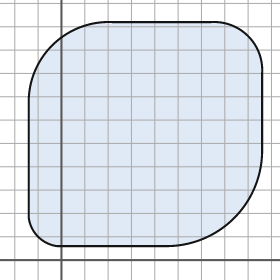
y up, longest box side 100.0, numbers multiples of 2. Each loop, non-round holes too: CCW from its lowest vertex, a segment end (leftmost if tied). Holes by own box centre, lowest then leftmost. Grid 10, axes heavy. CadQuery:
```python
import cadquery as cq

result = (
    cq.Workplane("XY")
    .moveTo(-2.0, 6.0)
    .lineTo(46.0, 6.0)
    .threePointArc((74.0, 18.0), (86.0, 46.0))
    .lineTo(86.0, 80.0)
    .threePointArc((80.0, 96.0), (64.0, 102.0))
    .lineTo(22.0, 102.0)
    .threePointArc((-4.0, 92.0), (-14.0, 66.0))
    .lineTo(-14.0, 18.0)
    .threePointArc((-10.0, 10.0), (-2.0, 6.0))
    .close()
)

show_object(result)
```